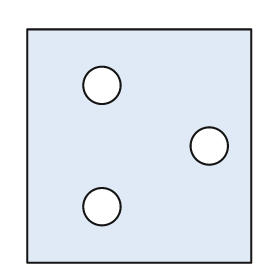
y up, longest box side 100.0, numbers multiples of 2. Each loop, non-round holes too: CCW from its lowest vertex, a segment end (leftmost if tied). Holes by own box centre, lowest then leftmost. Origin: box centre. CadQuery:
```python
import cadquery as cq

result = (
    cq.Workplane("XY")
    .moveTo(-48.0, -50.0)
    .lineTo(48.0, -50.0)
    .lineTo(48.0, 50.0)
    .lineTo(-48.0, 50.0)
    .close()
    .moveTo(-16.0, -26.0)
    .circle(8.0)
    .moveTo(30.0, 0.0)
    .circle(8.0)
    .moveTo(-16.0, 26.0)
    .circle(8.0)
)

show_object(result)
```